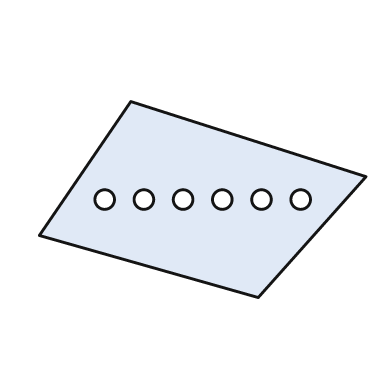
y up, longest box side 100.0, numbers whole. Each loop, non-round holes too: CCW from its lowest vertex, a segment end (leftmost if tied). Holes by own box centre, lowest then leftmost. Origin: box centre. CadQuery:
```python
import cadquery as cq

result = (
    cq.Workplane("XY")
    .moveTo(17.0, -30.0)
    .lineTo(50.0, 7.0)
    .lineTo(-22.0, 30.0)
    .lineTo(-50.0, -11.0)
    .close()
    .moveTo(-30.0, 0.0)
    .circle(3.0)
    .moveTo(-18.0, 0.0)
    .circle(3.0)
    .moveTo(-6.0, 0.0)
    .circle(3.0)
    .moveTo(6.0, 0.0)
    .circle(3.0)
    .moveTo(18.0, 0.0)
    .circle(3.0)
    .moveTo(30.0, 0.0)
    .circle(3.0)
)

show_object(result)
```